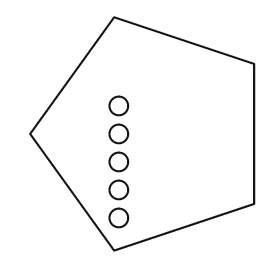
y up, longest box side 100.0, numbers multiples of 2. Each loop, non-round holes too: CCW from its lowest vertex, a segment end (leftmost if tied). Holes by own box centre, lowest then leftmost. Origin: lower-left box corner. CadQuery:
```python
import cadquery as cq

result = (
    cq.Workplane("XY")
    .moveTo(36.0, 0.0)
    .lineTo(96.0, 20.0)
    .lineTo(96.0, 80.0)
    .lineTo(36.0, 100.0)
    .lineTo(0.0, 50.0)
    .close()
    .moveTo(38.0, 14.0)
    .circle(4.0)
    .moveTo(38.0, 26.0)
    .circle(4.0)
    .moveTo(38.0, 38.0)
    .circle(4.0)
    .moveTo(38.0, 50.0)
    .circle(4.0)
    .moveTo(38.0, 62.0)
    .circle(4.0)
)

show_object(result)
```